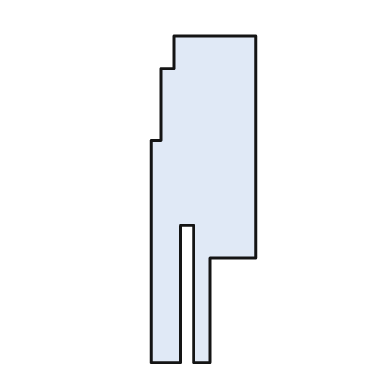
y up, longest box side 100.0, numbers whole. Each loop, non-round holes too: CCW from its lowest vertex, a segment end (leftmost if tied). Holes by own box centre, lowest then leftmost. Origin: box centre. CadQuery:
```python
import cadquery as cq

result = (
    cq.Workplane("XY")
    .moveTo(-16.0, -50.0)
    .lineTo(-7.0, -50.0)
    .lineTo(-7.0, -8.0)
    .lineTo(-3.0, -8.0)
    .lineTo(-3.0, -50.0)
    .lineTo(2.0, -50.0)
    .lineTo(2.0, -18.0)
    .lineTo(16.0, -18.0)
    .lineTo(16.0, 50.0)
    .lineTo(-9.0, 50.0)
    .lineTo(-9.0, 40.0)
    .lineTo(-13.0, 40.0)
    .lineTo(-13.0, 18.0)
    .lineTo(-16.0, 18.0)
    .close()
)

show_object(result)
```